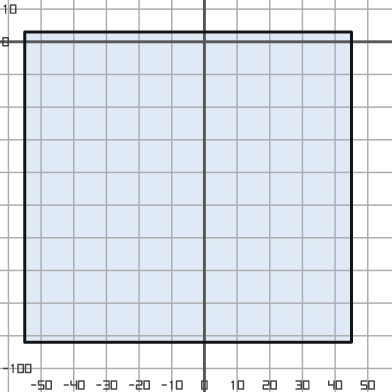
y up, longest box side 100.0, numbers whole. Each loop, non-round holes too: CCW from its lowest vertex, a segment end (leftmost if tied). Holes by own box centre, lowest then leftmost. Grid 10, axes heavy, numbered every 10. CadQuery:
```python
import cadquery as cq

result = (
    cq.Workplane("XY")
    .moveTo(-55.0, -92.0)
    .lineTo(45.0, -92.0)
    .lineTo(45.0, 3.0)
    .lineTo(-55.0, 3.0)
    .close()
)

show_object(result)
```